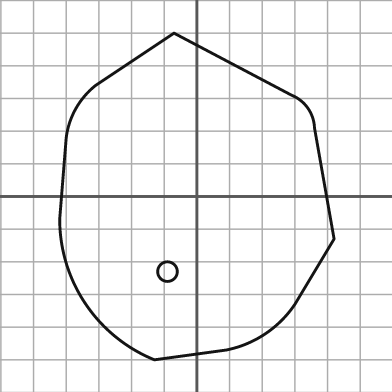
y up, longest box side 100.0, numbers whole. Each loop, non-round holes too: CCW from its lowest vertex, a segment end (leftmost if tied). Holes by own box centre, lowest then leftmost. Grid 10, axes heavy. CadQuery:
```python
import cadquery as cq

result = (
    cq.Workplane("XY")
    .moveTo(-13.0, -50.0)
    .lineTo(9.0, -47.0)
    .threePointArc((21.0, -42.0), (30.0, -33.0))
    .lineTo(42.0, -13.0)
    .lineTo(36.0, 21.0)
    .threePointArc((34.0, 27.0), (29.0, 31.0))
    .lineTo(-7.0, 50.0)
    .lineTo(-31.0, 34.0)
    .threePointArc((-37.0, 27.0), (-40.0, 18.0))
    .lineTo(-42.0, -7.0)
    .threePointArc((-34.0, -33.0), (-13.0, -50.0))
    .close()
    .moveTo(-9.0, -23.0)
    .circle(3.0)
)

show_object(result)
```